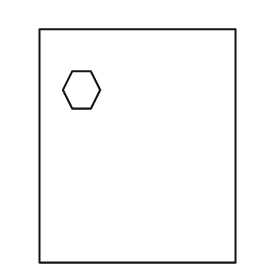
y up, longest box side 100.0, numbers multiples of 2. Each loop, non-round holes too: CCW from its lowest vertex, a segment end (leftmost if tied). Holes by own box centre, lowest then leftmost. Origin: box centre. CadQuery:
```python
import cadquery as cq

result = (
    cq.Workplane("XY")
    .moveTo(-42.0, -50.0)
    .lineTo(42.0, -50.0)
    .lineTo(42.0, 50.0)
    .lineTo(-42.0, 50.0)
    .close()
    .moveTo(-28.0, 16.0)
    .lineTo(-20.0, 16.0)
    .lineTo(-16.0, 24.0)
    .lineTo(-20.0, 32.0)
    .lineTo(-28.0, 32.0)
    .lineTo(-32.0, 24.0)
    .close()
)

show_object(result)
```